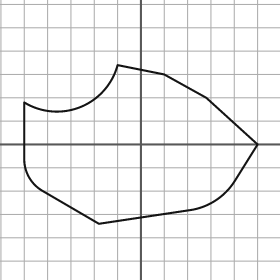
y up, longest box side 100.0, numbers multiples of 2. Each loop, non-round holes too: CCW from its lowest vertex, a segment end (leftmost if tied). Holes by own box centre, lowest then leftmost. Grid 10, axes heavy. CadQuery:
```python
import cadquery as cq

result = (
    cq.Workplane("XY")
    .moveTo(-18.0, -34.0)
    .lineTo(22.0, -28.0)
    .threePointArc((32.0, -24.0), (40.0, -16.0))
    .lineTo(50.0, 0.0)
    .lineTo(28.0, 20.0)
    .lineTo(10.0, 30.0)
    .lineTo(-10.0, 34.0)
    .threePointArc((-26.0, 16.0), (-50.0, 18.0))
    .lineTo(-50.0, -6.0)
    .threePointArc((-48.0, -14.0), (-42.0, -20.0))
    .close()
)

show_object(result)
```